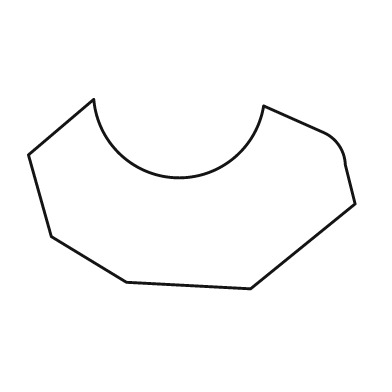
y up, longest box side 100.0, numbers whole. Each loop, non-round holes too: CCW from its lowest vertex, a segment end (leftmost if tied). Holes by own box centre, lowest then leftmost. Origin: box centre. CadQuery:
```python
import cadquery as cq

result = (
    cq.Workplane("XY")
    .moveTo(18.0, -29.0)
    .lineTo(50.0, -3.0)
    .lineTo(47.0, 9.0)
    .threePointArc((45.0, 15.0), (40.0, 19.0))
    .lineTo(22.0, 27.0)
    .threePointArc((-5.0, 5.0), (-30.0, 29.0))
    .lineTo(-50.0, 12.0)
    .lineTo(-43.0, -13.0)
    .lineTo(-20.0, -27.0)
    .close()
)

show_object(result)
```